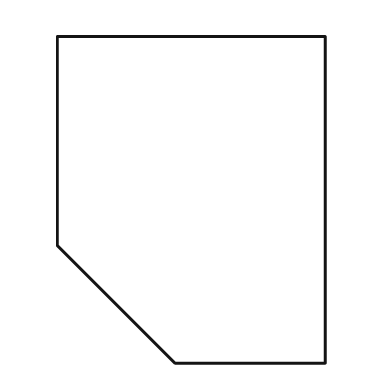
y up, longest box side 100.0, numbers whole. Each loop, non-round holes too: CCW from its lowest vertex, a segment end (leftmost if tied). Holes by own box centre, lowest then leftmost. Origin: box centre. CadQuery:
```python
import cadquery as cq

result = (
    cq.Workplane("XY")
    .moveTo(-5.0, -50.0)
    .lineTo(41.0, -50.0)
    .lineTo(41.0, 50.0)
    .lineTo(-41.0, 50.0)
    .lineTo(-41.0, -14.0)
    .close()
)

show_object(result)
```